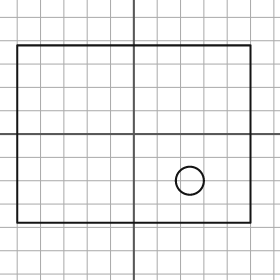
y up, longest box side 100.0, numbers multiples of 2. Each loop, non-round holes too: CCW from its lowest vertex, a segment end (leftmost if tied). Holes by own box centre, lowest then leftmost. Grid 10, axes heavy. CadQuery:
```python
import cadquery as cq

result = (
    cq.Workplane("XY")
    .moveTo(-50.0, -38.0)
    .lineTo(50.0, -38.0)
    .lineTo(50.0, 38.0)
    .lineTo(-50.0, 38.0)
    .close()
    .moveTo(24.0, -20.0)
    .circle(6.0)
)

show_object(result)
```